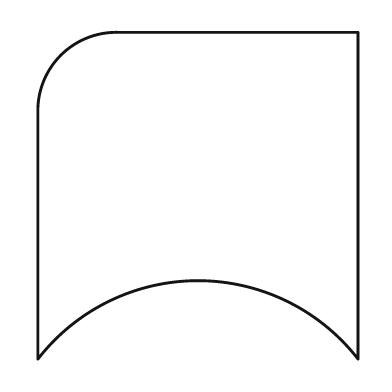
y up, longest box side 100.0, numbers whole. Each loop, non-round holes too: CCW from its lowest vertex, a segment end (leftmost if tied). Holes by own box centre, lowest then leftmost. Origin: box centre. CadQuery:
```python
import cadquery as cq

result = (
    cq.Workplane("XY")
    .moveTo(-49.0, -50.0)
    .threePointArc((0.0, -26.0), (49.0, -50.0))
    .lineTo(49.0, 50.0)
    .lineTo(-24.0, 50.0)
    .threePointArc((-42.0, 43.0), (-49.0, 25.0))
    .close()
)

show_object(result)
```